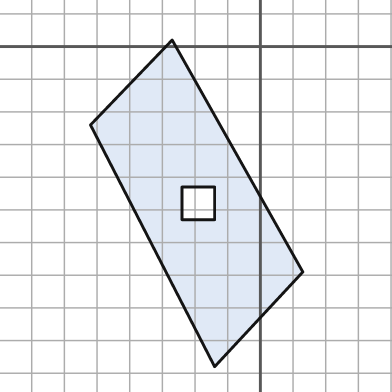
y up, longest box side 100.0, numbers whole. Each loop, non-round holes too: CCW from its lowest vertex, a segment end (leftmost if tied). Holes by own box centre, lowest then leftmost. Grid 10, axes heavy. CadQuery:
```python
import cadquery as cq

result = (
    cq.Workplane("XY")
    .moveTo(-14.0, -98.0)
    .lineTo(13.0, -69.0)
    .lineTo(-27.0, 2.0)
    .lineTo(-52.0, -24.0)
    .close()
    .moveTo(-24.0, -53.0)
    .lineTo(-14.0, -53.0)
    .lineTo(-14.0, -43.0)
    .lineTo(-24.0, -43.0)
    .close()
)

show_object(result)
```